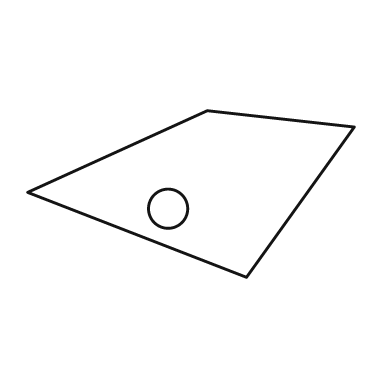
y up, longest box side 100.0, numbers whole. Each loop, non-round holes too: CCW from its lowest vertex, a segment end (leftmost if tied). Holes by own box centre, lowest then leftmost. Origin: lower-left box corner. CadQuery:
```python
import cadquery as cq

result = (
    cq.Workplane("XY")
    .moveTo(67.0, 0.0)
    .lineTo(100.0, 46.0)
    .lineTo(55.0, 51.0)
    .lineTo(0.0, 26.0)
    .close()
    .moveTo(43.0, 21.0)
    .circle(6.0)
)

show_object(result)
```